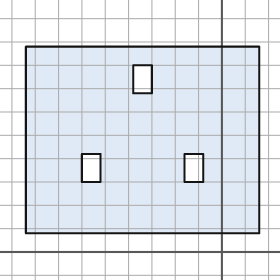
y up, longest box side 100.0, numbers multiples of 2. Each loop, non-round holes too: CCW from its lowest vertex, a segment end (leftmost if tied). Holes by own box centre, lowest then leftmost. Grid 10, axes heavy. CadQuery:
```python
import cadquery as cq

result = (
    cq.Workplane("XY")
    .moveTo(-84.0, 8.0)
    .lineTo(16.0, 8.0)
    .lineTo(16.0, 88.0)
    .lineTo(-84.0, 88.0)
    .close()
    .moveTo(-60.0, 30.0)
    .lineTo(-52.0, 30.0)
    .lineTo(-52.0, 42.0)
    .lineTo(-60.0, 42.0)
    .close()
    .moveTo(-16.0, 30.0)
    .lineTo(-8.0, 30.0)
    .lineTo(-8.0, 42.0)
    .lineTo(-16.0, 42.0)
    .close()
    .moveTo(-38.0, 68.0)
    .lineTo(-30.0, 68.0)
    .lineTo(-30.0, 80.0)
    .lineTo(-38.0, 80.0)
    .close()
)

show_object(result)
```